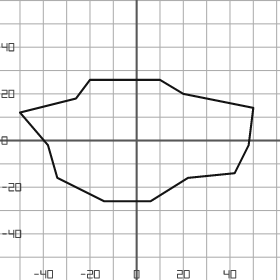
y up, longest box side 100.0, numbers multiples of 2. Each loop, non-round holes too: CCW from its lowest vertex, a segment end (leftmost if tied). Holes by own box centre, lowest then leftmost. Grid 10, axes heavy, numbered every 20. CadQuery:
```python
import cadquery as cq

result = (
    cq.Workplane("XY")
    .moveTo(-14.0, -26.0)
    .lineTo(6.0, -26.0)
    .lineTo(22.0, -16.0)
    .lineTo(42.0, -14.0)
    .lineTo(48.0, -2.0)
    .lineTo(50.0, 14.0)
    .lineTo(20.0, 20.0)
    .lineTo(10.0, 26.0)
    .lineTo(-20.0, 26.0)
    .lineTo(-26.0, 18.0)
    .lineTo(-50.0, 12.0)
    .lineTo(-38.0, -2.0)
    .lineTo(-34.0, -16.0)
    .close()
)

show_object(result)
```